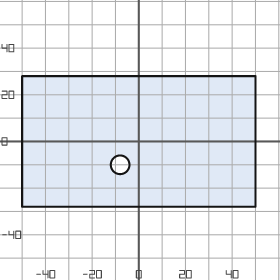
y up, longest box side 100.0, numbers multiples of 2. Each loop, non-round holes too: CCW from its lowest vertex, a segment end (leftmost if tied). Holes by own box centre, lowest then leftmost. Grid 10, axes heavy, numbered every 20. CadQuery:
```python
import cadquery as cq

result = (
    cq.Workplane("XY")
    .moveTo(-50.0, -28.0)
    .lineTo(50.0, -28.0)
    .lineTo(50.0, 28.0)
    .lineTo(-50.0, 28.0)
    .close()
    .moveTo(-8.0, -10.0)
    .circle(4.0)
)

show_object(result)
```